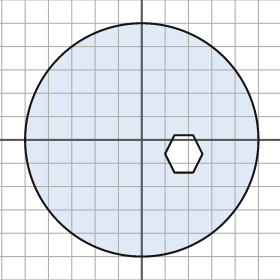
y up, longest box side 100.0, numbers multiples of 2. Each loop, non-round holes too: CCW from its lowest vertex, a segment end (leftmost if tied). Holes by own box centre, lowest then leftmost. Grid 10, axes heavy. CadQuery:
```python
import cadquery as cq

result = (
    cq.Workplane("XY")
    .moveTo(0.0, 0.0)
    .circle(50.0)
    .moveTo(14.0, -14.0)
    .lineTo(22.0, -14.0)
    .lineTo(26.0, -6.0)
    .lineTo(22.0, 2.0)
    .lineTo(14.0, 2.0)
    .lineTo(10.0, -6.0)
    .close()
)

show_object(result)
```